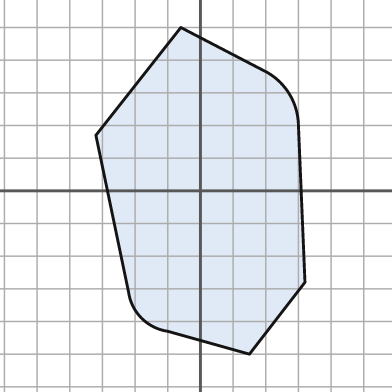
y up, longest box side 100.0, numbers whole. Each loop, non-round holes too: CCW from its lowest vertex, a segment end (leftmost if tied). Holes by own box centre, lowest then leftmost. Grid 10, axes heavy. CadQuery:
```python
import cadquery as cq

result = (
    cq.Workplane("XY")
    .moveTo(15.0, -50.0)
    .lineTo(32.0, -28.0)
    .lineTo(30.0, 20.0)
    .threePointArc((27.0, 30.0), (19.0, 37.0))
    .lineTo(-6.0, 50.0)
    .lineTo(-32.0, 17.0)
    .lineTo(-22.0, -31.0)
    .threePointArc((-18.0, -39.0), (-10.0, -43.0))
    .close()
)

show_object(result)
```